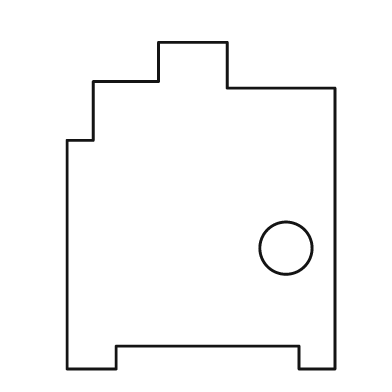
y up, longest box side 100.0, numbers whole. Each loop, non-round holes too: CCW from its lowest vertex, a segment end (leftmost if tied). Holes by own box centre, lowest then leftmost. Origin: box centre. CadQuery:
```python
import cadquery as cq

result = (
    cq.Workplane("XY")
    .moveTo(-41.0, -50.0)
    .lineTo(-26.0, -50.0)
    .lineTo(-26.0, -43.0)
    .lineTo(30.0, -43.0)
    .lineTo(30.0, -50.0)
    .lineTo(41.0, -50.0)
    .lineTo(41.0, 36.0)
    .lineTo(8.0, 36.0)
    .lineTo(8.0, 50.0)
    .lineTo(-13.0, 50.0)
    .lineTo(-13.0, 38.0)
    .lineTo(-33.0, 38.0)
    .lineTo(-33.0, 20.0)
    .lineTo(-41.0, 20.0)
    .close()
    .moveTo(26.0, -13.0)
    .circle(8.0)
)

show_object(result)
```